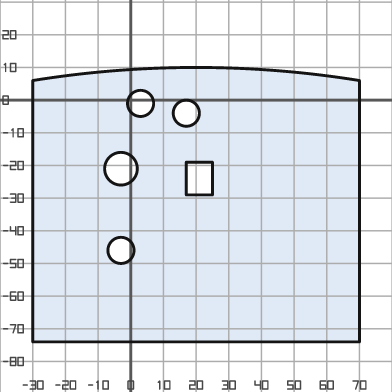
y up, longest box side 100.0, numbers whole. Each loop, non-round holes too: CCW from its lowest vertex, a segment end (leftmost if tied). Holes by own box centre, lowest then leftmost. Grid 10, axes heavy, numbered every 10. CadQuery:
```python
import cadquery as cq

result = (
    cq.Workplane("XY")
    .moveTo(-30.0, -74.0)
    .lineTo(70.0, -74.0)
    .lineTo(70.0, 6.0)
    .threePointArc((20.0, 10.0), (-30.0, 6.0))
    .close()
    .moveTo(-3.0, -46.0)
    .circle(4.0)
    .moveTo(17.0, -29.0)
    .lineTo(25.0, -29.0)
    .lineTo(25.0, -19.0)
    .lineTo(17.0, -19.0)
    .close()
    .moveTo(-3.0, -21.0)
    .circle(5.0)
    .moveTo(17.0, -4.0)
    .circle(4.0)
    .moveTo(3.0, -1.0)
    .circle(4.0)
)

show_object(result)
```